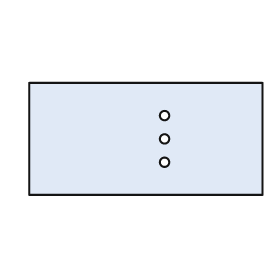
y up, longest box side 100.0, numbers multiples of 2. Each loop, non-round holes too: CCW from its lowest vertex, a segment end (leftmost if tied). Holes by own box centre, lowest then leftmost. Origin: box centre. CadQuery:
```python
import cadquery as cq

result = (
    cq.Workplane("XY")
    .moveTo(-50.0, -24.0)
    .lineTo(50.0, -24.0)
    .lineTo(50.0, 24.0)
    .lineTo(-50.0, 24.0)
    .close()
    .moveTo(8.0, -10.0)
    .circle(2.0)
    .moveTo(8.0, 0.0)
    .circle(2.0)
    .moveTo(8.0, 10.0)
    .circle(2.0)
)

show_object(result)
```